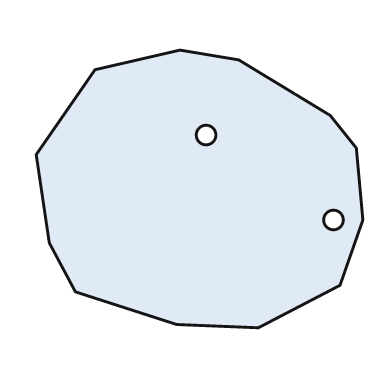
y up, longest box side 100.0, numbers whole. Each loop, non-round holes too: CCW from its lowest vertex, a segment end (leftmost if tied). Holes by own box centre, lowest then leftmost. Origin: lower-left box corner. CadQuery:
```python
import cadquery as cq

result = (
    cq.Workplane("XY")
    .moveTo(68.0, 0.0)
    .lineTo(93.0, 13.0)
    .lineTo(100.0, 33.0)
    .lineTo(98.0, 55.0)
    .lineTo(90.0, 65.0)
    .lineTo(62.0, 82.0)
    .lineTo(44.0, 85.0)
    .lineTo(18.0, 79.0)
    .lineTo(0.0, 53.0)
    .lineTo(4.0, 26.0)
    .lineTo(12.0, 11.0)
    .lineTo(43.0, 1.0)
    .close()
    .moveTo(91.0, 33.0)
    .circle(3.0)
    .moveTo(52.0, 59.0)
    .circle(3.0)
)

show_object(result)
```